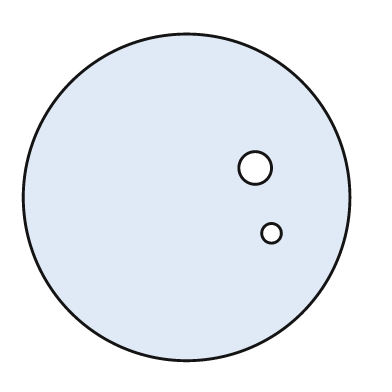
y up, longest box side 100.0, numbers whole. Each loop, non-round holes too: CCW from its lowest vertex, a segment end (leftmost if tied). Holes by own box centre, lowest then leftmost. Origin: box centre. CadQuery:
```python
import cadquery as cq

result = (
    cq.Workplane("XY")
    .moveTo(0.0, 0.0)
    .circle(50.0)
    .moveTo(26.0, -11.0)
    .circle(3.0)
    .moveTo(21.0, 9.0)
    .circle(5.0)
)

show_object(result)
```